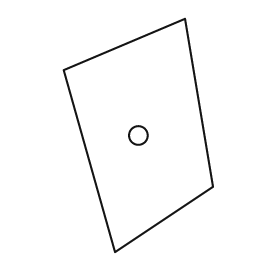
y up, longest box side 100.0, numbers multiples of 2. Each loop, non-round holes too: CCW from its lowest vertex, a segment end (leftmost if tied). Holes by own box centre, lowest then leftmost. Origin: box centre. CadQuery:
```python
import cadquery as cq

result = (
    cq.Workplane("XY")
    .moveTo(-10.0, -50.0)
    .lineTo(32.0, -22.0)
    .lineTo(20.0, 50.0)
    .lineTo(-32.0, 28.0)
    .close()
    .moveTo(0.0, 0.0)
    .circle(4.0)
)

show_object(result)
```